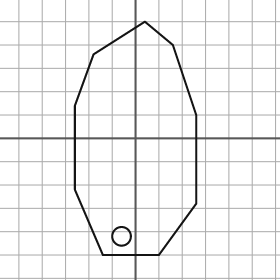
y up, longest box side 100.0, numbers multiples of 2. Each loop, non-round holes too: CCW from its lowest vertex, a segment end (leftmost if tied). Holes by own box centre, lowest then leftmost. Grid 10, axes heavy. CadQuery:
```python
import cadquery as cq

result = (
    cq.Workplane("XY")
    .moveTo(-14.0, -50.0)
    .lineTo(10.0, -50.0)
    .lineTo(26.0, -28.0)
    .lineTo(26.0, 10.0)
    .lineTo(16.0, 40.0)
    .lineTo(4.0, 50.0)
    .lineTo(-18.0, 36.0)
    .lineTo(-26.0, 14.0)
    .lineTo(-26.0, -22.0)
    .close()
    .moveTo(-6.0, -42.0)
    .circle(4.0)
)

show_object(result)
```